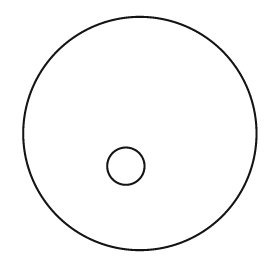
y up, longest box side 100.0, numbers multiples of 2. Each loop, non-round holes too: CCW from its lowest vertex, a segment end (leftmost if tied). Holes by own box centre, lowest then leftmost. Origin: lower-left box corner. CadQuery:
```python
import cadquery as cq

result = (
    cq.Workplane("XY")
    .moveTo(50.0, 50.0)
    .circle(50.0)
    .moveTo(44.0, 36.0)
    .circle(8.0)
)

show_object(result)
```